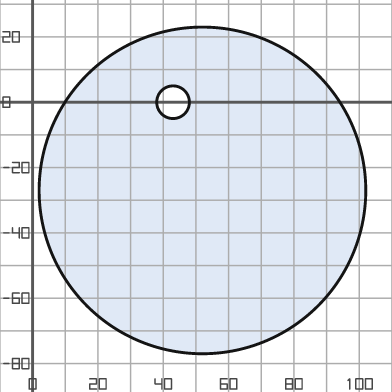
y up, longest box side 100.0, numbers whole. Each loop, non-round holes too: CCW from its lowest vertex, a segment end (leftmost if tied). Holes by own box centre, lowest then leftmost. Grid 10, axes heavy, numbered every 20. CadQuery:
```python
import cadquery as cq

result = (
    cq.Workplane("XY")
    .moveTo(52.0, -27.0)
    .circle(50.0)
    .moveTo(43.0, 0.0)
    .circle(5.0)
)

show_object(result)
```